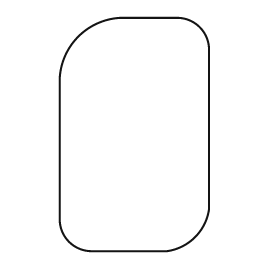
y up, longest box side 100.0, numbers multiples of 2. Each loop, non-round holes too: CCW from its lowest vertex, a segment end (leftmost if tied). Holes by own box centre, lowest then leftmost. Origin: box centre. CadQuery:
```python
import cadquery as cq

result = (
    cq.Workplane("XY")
    .moveTo(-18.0, -50.0)
    .lineTo(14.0, -50.0)
    .threePointArc((26.0, -44.0), (32.0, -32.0))
    .lineTo(32.0, 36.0)
    .threePointArc((28.0, 46.0), (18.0, 50.0))
    .lineTo(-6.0, 50.0)
    .threePointArc((-24.0, 42.0), (-32.0, 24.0))
    .lineTo(-32.0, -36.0)
    .threePointArc((-28.0, -46.0), (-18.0, -50.0))
    .close()
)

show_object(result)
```